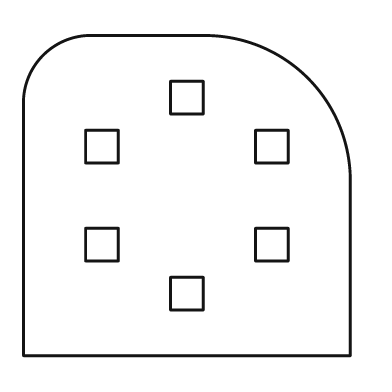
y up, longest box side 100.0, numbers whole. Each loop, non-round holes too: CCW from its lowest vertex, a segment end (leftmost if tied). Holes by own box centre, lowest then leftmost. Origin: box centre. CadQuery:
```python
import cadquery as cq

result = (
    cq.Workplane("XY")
    .moveTo(-50.0, -49.0)
    .lineTo(50.0, -49.0)
    .lineTo(50.0, 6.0)
    .threePointArc((37.0, 36.0), (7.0, 49.0))
    .lineTo(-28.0, 49.0)
    .threePointArc((-44.0, 43.0), (-50.0, 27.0))
    .close()
    .moveTo(-5.0, -35.0)
    .lineTo(5.0, -35.0)
    .lineTo(5.0, -25.0)
    .lineTo(-5.0, -25.0)
    .close()
    .moveTo(-31.0, -20.0)
    .lineTo(-21.0, -20.0)
    .lineTo(-21.0, -10.0)
    .lineTo(-31.0, -10.0)
    .close()
    .moveTo(21.0, -20.0)
    .lineTo(31.0, -20.0)
    .lineTo(31.0, -10.0)
    .lineTo(21.0, -10.0)
    .close()
    .moveTo(-31.0, 10.0)
    .lineTo(-21.0, 10.0)
    .lineTo(-21.0, 20.0)
    .lineTo(-31.0, 20.0)
    .close()
    .moveTo(21.0, 10.0)
    .lineTo(31.0, 10.0)
    .lineTo(31.0, 20.0)
    .lineTo(21.0, 20.0)
    .close()
    .moveTo(-5.0, 25.0)
    .lineTo(5.0, 25.0)
    .lineTo(5.0, 35.0)
    .lineTo(-5.0, 35.0)
    .close()
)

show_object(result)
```